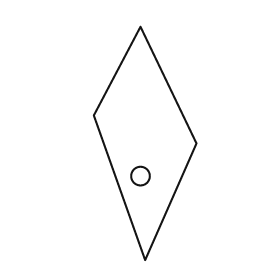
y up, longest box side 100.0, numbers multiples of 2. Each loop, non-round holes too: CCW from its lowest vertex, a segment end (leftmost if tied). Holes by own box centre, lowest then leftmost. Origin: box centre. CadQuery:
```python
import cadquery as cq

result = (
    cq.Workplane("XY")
    .moveTo(0.0, -50.0)
    .lineTo(22.0, 0.0)
    .lineTo(-2.0, 50.0)
    .lineTo(-22.0, 12.0)
    .close()
    .moveTo(-2.0, -14.0)
    .circle(4.0)
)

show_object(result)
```